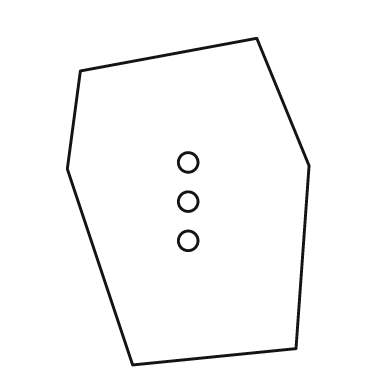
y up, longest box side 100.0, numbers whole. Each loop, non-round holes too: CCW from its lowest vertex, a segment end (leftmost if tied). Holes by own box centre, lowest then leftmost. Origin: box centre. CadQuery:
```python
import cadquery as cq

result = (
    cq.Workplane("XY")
    .moveTo(-17.0, -50.0)
    .lineTo(33.0, -45.0)
    .lineTo(37.0, 11.0)
    .lineTo(21.0, 50.0)
    .lineTo(-33.0, 40.0)
    .lineTo(-37.0, 10.0)
    .close()
    .moveTo(0.0, -12.0)
    .circle(3.0)
    .moveTo(0.0, 0.0)
    .circle(3.0)
    .moveTo(0.0, 12.0)
    .circle(3.0)
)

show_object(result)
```